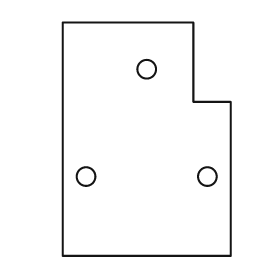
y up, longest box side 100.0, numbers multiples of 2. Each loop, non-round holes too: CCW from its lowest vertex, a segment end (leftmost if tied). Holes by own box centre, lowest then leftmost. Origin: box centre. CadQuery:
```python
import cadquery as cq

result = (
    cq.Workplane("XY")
    .moveTo(-36.0, -50.0)
    .lineTo(36.0, -50.0)
    .lineTo(36.0, 16.0)
    .lineTo(20.0, 16.0)
    .lineTo(20.0, 50.0)
    .lineTo(-36.0, 50.0)
    .close()
    .moveTo(-26.0, -16.0)
    .circle(4.0)
    .moveTo(26.0, -16.0)
    .circle(4.0)
    .moveTo(0.0, 30.0)
    .circle(4.0)
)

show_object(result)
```